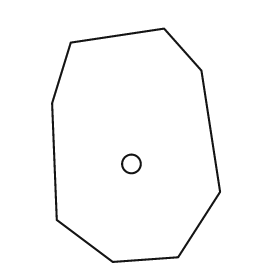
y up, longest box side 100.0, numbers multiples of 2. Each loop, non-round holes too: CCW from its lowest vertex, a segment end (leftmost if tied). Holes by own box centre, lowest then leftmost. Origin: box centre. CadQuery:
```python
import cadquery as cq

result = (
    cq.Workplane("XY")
    .moveTo(-10.0, -50.0)
    .lineTo(18.0, -48.0)
    .lineTo(36.0, -20.0)
    .lineTo(28.0, 32.0)
    .lineTo(12.0, 50.0)
    .lineTo(-28.0, 44.0)
    .lineTo(-36.0, 18.0)
    .lineTo(-34.0, -32.0)
    .close()
    .moveTo(-2.0, -8.0)
    .circle(4.0)
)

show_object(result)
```